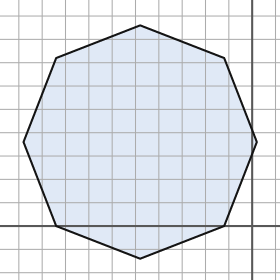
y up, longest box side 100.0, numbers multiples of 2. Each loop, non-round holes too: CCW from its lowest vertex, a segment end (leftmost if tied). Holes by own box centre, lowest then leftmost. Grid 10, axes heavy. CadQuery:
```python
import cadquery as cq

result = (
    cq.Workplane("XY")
    .moveTo(-48.0, -14.0)
    .lineTo(-12.0, 0.0)
    .lineTo(2.0, 36.0)
    .lineTo(-12.0, 72.0)
    .lineTo(-48.0, 86.0)
    .lineTo(-84.0, 72.0)
    .lineTo(-98.0, 36.0)
    .lineTo(-84.0, 0.0)
    .close()
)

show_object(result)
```